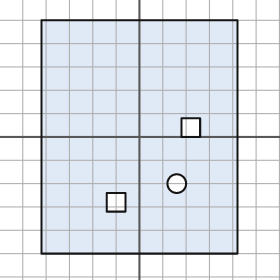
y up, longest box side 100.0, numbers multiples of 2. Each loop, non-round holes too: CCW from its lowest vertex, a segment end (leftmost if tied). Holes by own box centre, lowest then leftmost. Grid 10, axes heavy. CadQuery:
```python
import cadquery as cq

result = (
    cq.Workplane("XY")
    .moveTo(-42.0, -50.0)
    .lineTo(42.0, -50.0)
    .lineTo(42.0, 50.0)
    .lineTo(-42.0, 50.0)
    .close()
    .moveTo(-14.0, -32.0)
    .lineTo(-6.0, -32.0)
    .lineTo(-6.0, -24.0)
    .lineTo(-14.0, -24.0)
    .close()
    .moveTo(16.0, -20.0)
    .circle(4.0)
    .moveTo(18.0, 0.0)
    .lineTo(26.0, 0.0)
    .lineTo(26.0, 8.0)
    .lineTo(18.0, 8.0)
    .close()
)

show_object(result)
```